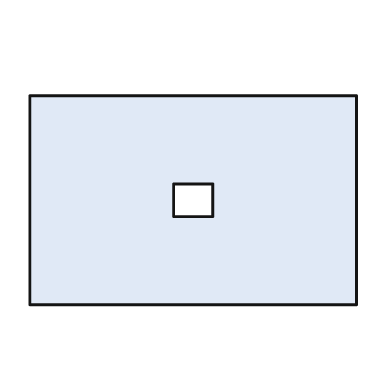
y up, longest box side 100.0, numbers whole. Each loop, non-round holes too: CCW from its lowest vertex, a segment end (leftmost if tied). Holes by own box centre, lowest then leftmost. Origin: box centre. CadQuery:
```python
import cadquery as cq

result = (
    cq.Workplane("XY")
    .moveTo(-50.0, -32.0)
    .lineTo(50.0, -32.0)
    .lineTo(50.0, 32.0)
    .lineTo(-50.0, 32.0)
    .close()
    .moveTo(-6.0, -5.0)
    .lineTo(6.0, -5.0)
    .lineTo(6.0, 5.0)
    .lineTo(-6.0, 5.0)
    .close()
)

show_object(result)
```